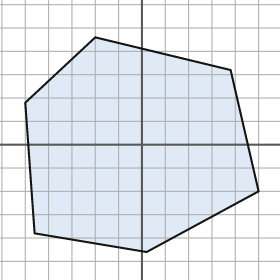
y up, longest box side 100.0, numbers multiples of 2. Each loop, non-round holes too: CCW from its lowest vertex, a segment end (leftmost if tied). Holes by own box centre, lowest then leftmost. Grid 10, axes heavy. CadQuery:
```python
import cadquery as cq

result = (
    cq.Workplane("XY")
    .moveTo(2.0, -46.0)
    .lineTo(50.0, -20.0)
    .lineTo(38.0, 32.0)
    .lineTo(-20.0, 46.0)
    .lineTo(-50.0, 18.0)
    .lineTo(-46.0, -38.0)
    .close()
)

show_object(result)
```